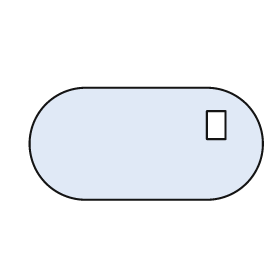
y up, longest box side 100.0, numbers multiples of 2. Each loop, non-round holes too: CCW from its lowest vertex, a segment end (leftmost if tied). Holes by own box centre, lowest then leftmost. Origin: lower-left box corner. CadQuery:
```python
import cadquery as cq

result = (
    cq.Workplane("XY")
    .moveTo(24.0, 0.0)
    .lineTo(76.0, 0.0)
    .threePointArc((100.0, 24.0), (76.0, 48.0))
    .lineTo(24.0, 48.0)
    .threePointArc((0.0, 24.0), (24.0, 0.0))
    .close()
    .moveTo(76.0, 26.0)
    .lineTo(84.0, 26.0)
    .lineTo(84.0, 38.0)
    .lineTo(76.0, 38.0)
    .close()
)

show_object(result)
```